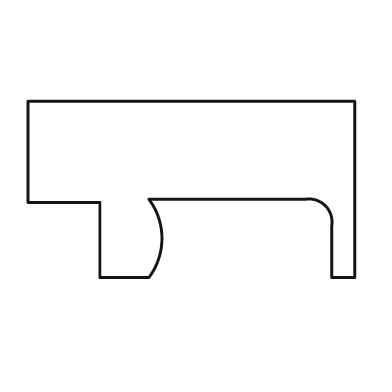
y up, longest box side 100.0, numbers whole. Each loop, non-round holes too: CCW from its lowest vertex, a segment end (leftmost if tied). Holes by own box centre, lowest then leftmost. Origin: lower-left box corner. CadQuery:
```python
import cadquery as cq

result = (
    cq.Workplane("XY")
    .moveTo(22.0, 0.0)
    .lineTo(37.0, 0.0)
    .threePointArc((41.0, 12.0), (37.0, 24.0))
    .lineTo(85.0, 24.0)
    .threePointArc((91.0, 22.0), (93.0, 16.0))
    .lineTo(93.0, 0.0)
    .lineTo(100.0, 0.0)
    .lineTo(100.0, 54.0)
    .lineTo(0.0, 54.0)
    .lineTo(0.0, 23.0)
    .lineTo(22.0, 23.0)
    .close()
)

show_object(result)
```